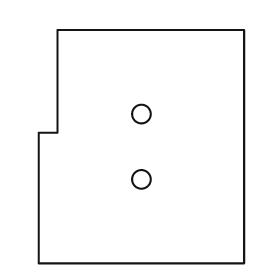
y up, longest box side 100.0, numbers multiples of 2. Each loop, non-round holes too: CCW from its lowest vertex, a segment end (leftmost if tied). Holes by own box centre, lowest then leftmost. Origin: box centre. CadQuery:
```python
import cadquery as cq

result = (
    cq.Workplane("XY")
    .moveTo(-44.0, -50.0)
    .lineTo(44.0, -50.0)
    .lineTo(44.0, 50.0)
    .lineTo(-36.0, 50.0)
    .lineTo(-36.0, 6.0)
    .lineTo(-44.0, 6.0)
    .close()
    .moveTo(0.0, -14.0)
    .circle(4.0)
    .moveTo(0.0, 14.0)
    .circle(4.0)
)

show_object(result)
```